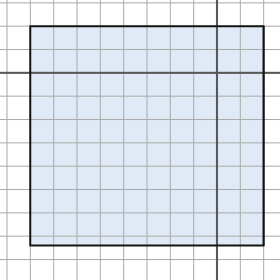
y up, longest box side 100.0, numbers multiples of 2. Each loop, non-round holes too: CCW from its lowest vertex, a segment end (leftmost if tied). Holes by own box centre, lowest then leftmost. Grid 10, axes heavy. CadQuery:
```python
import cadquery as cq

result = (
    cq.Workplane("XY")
    .moveTo(-80.0, -74.0)
    .lineTo(20.0, -74.0)
    .lineTo(20.0, 20.0)
    .lineTo(-80.0, 20.0)
    .close()
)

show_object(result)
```